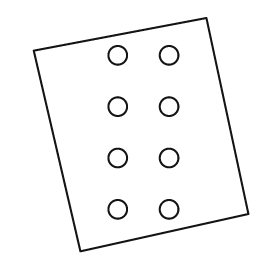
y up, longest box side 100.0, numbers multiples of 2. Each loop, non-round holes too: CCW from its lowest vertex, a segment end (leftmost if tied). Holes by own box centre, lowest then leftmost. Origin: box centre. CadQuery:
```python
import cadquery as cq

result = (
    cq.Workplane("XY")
    .moveTo(-26.0, -50.0)
    .lineTo(46.0, -34.0)
    .lineTo(28.0, 50.0)
    .lineTo(-46.0, 36.0)
    .close()
    .moveTo(-10.0, -32.0)
    .circle(4.0)
    .moveTo(12.0, -32.0)
    .circle(4.0)
    .moveTo(-10.0, -10.0)
    .circle(4.0)
    .moveTo(12.0, -10.0)
    .circle(4.0)
    .moveTo(-10.0, 12.0)
    .circle(4.0)
    .moveTo(12.0, 12.0)
    .circle(4.0)
    .moveTo(-10.0, 34.0)
    .circle(4.0)
    .moveTo(12.0, 34.0)
    .circle(4.0)
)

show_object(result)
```